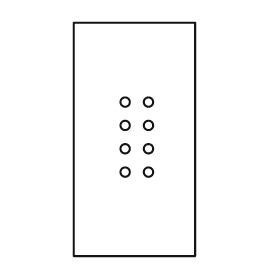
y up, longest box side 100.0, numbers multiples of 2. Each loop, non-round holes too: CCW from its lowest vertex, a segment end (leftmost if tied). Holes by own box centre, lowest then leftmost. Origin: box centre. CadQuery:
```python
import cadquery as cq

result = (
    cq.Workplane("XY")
    .moveTo(-26.0, -50.0)
    .lineTo(26.0, -50.0)
    .lineTo(26.0, 50.0)
    .lineTo(-26.0, 50.0)
    .close()
    .moveTo(-4.0, -14.0)
    .circle(2.0)
    .moveTo(6.0, -14.0)
    .circle(2.0)
    .moveTo(-4.0, -4.0)
    .circle(2.0)
    .moveTo(6.0, -4.0)
    .circle(2.0)
    .moveTo(-4.0, 6.0)
    .circle(2.0)
    .moveTo(6.0, 6.0)
    .circle(2.0)
    .moveTo(-4.0, 16.0)
    .circle(2.0)
    .moveTo(6.0, 16.0)
    .circle(2.0)
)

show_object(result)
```